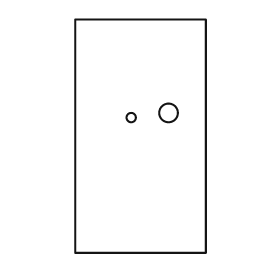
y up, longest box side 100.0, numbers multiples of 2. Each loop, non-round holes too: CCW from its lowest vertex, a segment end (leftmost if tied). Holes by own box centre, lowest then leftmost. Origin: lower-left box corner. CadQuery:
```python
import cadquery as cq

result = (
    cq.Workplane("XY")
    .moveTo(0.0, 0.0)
    .lineTo(56.0, 0.0)
    .lineTo(56.0, 100.0)
    .lineTo(0.0, 100.0)
    .close()
    .moveTo(24.0, 58.0)
    .circle(2.0)
    .moveTo(40.0, 60.0)
    .circle(4.0)
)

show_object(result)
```